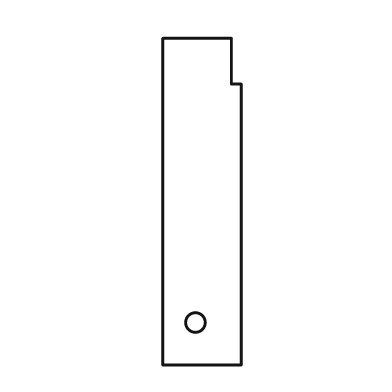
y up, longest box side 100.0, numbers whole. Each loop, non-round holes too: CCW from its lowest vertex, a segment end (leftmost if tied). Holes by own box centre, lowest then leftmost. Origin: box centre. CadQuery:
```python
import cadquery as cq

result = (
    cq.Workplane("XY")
    .moveTo(-12.0, -50.0)
    .lineTo(12.0, -50.0)
    .lineTo(12.0, 36.0)
    .lineTo(9.0, 36.0)
    .lineTo(9.0, 50.0)
    .lineTo(-12.0, 50.0)
    .close()
    .moveTo(-2.0, -37.0)
    .circle(3.0)
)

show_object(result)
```